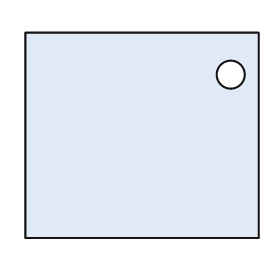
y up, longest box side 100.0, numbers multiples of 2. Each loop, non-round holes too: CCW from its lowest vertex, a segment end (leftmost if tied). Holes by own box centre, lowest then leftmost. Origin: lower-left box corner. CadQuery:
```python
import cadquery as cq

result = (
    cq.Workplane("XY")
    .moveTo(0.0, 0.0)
    .lineTo(100.0, 0.0)
    .lineTo(100.0, 88.0)
    .lineTo(0.0, 88.0)
    .close()
    .moveTo(88.0, 70.0)
    .circle(6.0)
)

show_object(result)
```